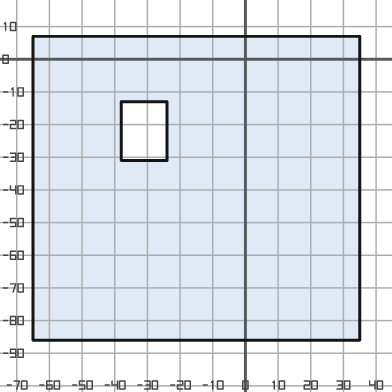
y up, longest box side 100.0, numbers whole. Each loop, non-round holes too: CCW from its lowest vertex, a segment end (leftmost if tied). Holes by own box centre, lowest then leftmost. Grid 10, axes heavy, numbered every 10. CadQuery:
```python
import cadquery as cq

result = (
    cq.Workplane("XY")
    .moveTo(-65.0, -86.0)
    .lineTo(35.0, -86.0)
    .lineTo(35.0, 7.0)
    .lineTo(-65.0, 7.0)
    .close()
    .moveTo(-38.0, -31.0)
    .lineTo(-24.0, -31.0)
    .lineTo(-24.0, -13.0)
    .lineTo(-38.0, -13.0)
    .close()
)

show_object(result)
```